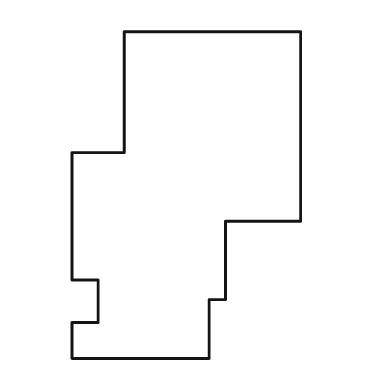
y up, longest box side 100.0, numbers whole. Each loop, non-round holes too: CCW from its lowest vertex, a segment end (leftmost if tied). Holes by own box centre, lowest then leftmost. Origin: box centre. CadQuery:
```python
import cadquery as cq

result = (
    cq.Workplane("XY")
    .moveTo(-35.0, -50.0)
    .lineTo(7.0, -50.0)
    .lineTo(7.0, -32.0)
    .lineTo(12.0, -32.0)
    .lineTo(12.0, -8.0)
    .lineTo(35.0, -8.0)
    .lineTo(35.0, 50.0)
    .lineTo(-19.0, 50.0)
    .lineTo(-19.0, 13.0)
    .lineTo(-35.0, 13.0)
    .lineTo(-35.0, -26.0)
    .lineTo(-27.0, -26.0)
    .lineTo(-27.0, -39.0)
    .lineTo(-35.0, -39.0)
    .close()
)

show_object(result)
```